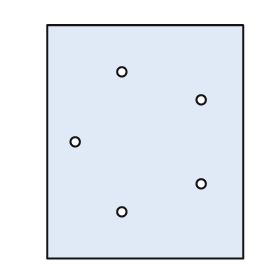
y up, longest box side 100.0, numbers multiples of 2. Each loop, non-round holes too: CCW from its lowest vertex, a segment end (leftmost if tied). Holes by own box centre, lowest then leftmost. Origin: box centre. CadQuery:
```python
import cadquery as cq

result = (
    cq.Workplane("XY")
    .moveTo(-42.0, -50.0)
    .lineTo(42.0, -50.0)
    .lineTo(42.0, 50.0)
    .lineTo(-42.0, 50.0)
    .close()
    .moveTo(-10.0, -30.0)
    .circle(2.0)
    .moveTo(24.0, -18.0)
    .circle(2.0)
    .moveTo(-30.0, 0.0)
    .circle(2.0)
    .moveTo(24.0, 18.0)
    .circle(2.0)
    .moveTo(-10.0, 30.0)
    .circle(2.0)
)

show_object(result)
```